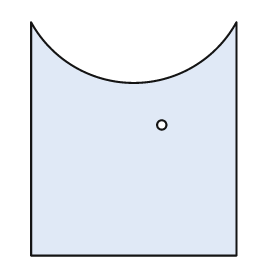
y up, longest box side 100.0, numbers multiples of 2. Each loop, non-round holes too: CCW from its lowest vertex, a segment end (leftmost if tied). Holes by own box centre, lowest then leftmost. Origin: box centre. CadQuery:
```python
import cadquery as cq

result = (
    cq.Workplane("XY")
    .moveTo(-44.0, -50.0)
    .lineTo(44.0, -50.0)
    .lineTo(44.0, 50.0)
    .threePointArc((0.0, 24.0), (-44.0, 50.0))
    .close()
    .moveTo(12.0, 6.0)
    .circle(2.0)
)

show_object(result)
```